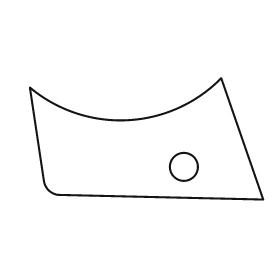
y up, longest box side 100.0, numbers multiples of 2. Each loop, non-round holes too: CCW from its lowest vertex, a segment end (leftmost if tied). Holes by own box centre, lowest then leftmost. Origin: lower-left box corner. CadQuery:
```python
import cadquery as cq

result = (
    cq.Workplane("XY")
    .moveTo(100.0, 0.0)
    .lineTo(82.0, 52.0)
    .threePointArc((42.0, 34.0), (0.0, 48.0))
    .lineTo(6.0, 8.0)
    .threePointArc((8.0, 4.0), (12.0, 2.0))
    .close()
    .moveTo(66.0, 14.0)
    .circle(6.0)
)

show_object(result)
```